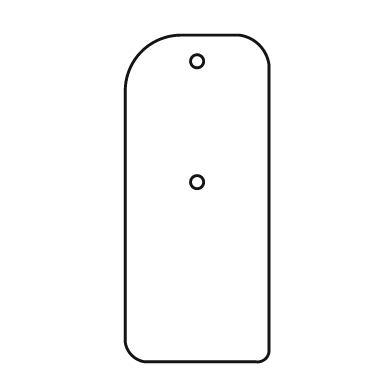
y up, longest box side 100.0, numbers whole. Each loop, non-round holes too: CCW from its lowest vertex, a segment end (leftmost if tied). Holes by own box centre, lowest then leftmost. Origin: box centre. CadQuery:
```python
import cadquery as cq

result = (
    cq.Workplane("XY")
    .moveTo(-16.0, -50.0)
    .lineTo(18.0, -50.0)
    .threePointArc((21.0, -49.0), (22.0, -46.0))
    .lineTo(22.0, 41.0)
    .threePointArc((19.0, 47.0), (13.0, 50.0))
    .lineTo(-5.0, 50.0)
    .threePointArc((-17.0, 45.0), (-22.0, 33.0))
    .lineTo(-22.0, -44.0)
    .threePointArc((-20.0, -48.0), (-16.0, -50.0))
    .close()
    .moveTo(0.0, 5.0)
    .circle(2.0)
    .moveTo(0.0, 42.0)
    .circle(2.0)
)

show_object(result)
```